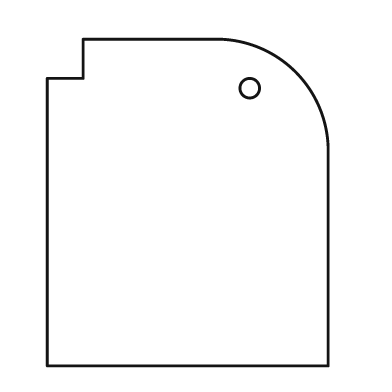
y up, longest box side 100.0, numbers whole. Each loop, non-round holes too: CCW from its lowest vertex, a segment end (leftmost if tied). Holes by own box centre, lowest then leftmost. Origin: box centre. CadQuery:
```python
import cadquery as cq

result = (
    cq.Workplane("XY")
    .moveTo(-43.0, -50.0)
    .lineTo(43.0, -50.0)
    .lineTo(43.0, 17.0)
    .threePointArc((33.0, 40.0), (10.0, 50.0))
    .lineTo(-32.0, 50.0)
    .lineTo(-32.0, 38.0)
    .lineTo(-43.0, 38.0)
    .close()
    .moveTo(19.0, 35.0)
    .circle(3.0)
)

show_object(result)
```